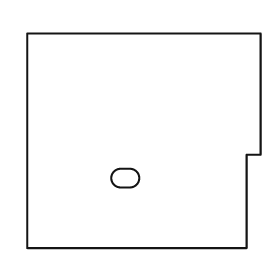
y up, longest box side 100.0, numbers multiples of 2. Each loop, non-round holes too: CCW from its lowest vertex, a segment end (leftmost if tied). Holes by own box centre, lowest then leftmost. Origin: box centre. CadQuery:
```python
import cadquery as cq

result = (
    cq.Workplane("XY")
    .moveTo(-50.0, -46.0)
    .lineTo(44.0, -46.0)
    .lineTo(44.0, -6.0)
    .lineTo(50.0, -6.0)
    .lineTo(50.0, 46.0)
    .lineTo(-50.0, 46.0)
    .close()
    .moveTo(-10.0, -20.0)
    .lineTo(-6.0, -20.0)
    .threePointArc((-2.0, -16.0), (-6.0, -12.0))
    .lineTo(-10.0, -12.0)
    .threePointArc((-14.0, -16.0), (-10.0, -20.0))
    .close()
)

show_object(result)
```